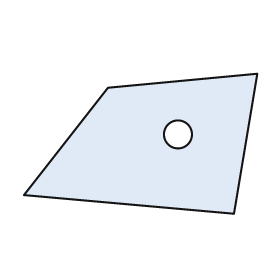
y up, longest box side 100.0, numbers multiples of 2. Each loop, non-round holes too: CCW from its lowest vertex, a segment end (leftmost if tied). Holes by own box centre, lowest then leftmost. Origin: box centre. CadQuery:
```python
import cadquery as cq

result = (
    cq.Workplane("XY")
    .moveTo(40.0, -30.0)
    .lineTo(50.0, 30.0)
    .lineTo(-14.0, 24.0)
    .lineTo(-50.0, -22.0)
    .close()
    .moveTo(16.0, 4.0)
    .circle(6.0)
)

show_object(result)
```